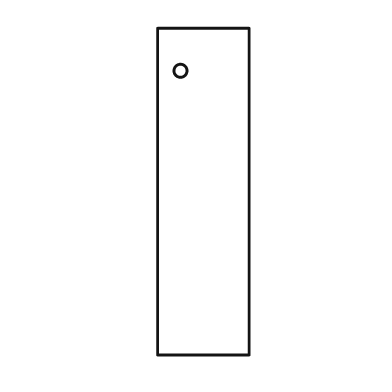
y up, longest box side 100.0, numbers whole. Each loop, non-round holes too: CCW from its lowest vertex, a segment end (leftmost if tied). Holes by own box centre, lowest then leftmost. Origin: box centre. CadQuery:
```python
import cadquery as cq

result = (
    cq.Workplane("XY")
    .moveTo(-14.0, -50.0)
    .lineTo(14.0, -50.0)
    .lineTo(14.0, 50.0)
    .lineTo(-14.0, 50.0)
    .close()
    .moveTo(-7.0, 37.0)
    .circle(2.0)
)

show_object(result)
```